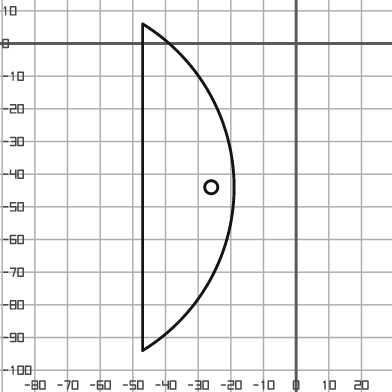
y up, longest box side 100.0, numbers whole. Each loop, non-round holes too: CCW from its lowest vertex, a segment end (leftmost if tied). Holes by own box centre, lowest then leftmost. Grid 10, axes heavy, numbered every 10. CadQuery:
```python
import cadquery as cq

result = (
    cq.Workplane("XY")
    .moveTo(-47.0, -94.0)
    .threePointArc((-19.0, -44.0), (-47.0, 6.0))
    .close()
    .moveTo(-26.0, -44.0)
    .circle(2.0)
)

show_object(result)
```